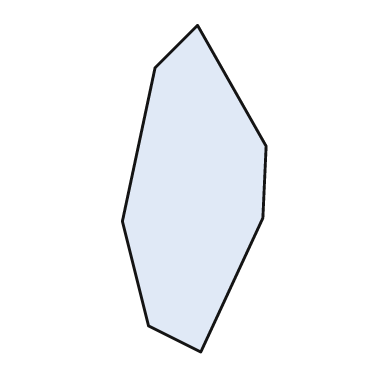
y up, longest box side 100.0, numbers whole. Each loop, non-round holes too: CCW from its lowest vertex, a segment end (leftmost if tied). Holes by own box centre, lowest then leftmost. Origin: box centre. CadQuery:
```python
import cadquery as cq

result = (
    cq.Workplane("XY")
    .moveTo(2.0, -50.0)
    .lineTo(21.0, -9.0)
    .lineTo(22.0, 13.0)
    .lineTo(1.0, 50.0)
    .lineTo(-12.0, 37.0)
    .lineTo(-22.0, -10.0)
    .lineTo(-14.0, -42.0)
    .close()
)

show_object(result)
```